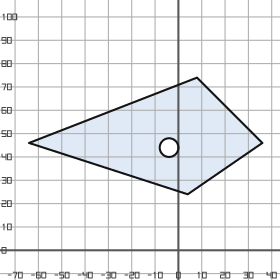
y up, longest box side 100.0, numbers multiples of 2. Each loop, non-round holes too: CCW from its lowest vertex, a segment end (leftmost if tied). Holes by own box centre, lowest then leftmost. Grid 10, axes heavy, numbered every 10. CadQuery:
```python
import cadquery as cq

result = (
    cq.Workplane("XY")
    .moveTo(4.0, 24.0)
    .lineTo(36.0, 46.0)
    .lineTo(8.0, 74.0)
    .lineTo(-64.0, 46.0)
    .close()
    .moveTo(-4.0, 44.0)
    .circle(4.0)
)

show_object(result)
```